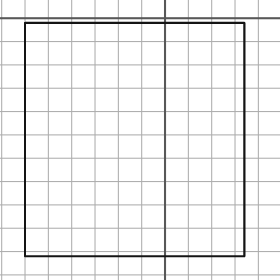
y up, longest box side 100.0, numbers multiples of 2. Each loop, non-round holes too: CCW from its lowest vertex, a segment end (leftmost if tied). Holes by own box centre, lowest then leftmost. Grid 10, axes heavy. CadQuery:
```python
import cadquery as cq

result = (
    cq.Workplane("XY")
    .moveTo(-60.0, -102.0)
    .lineTo(34.0, -102.0)
    .lineTo(34.0, -2.0)
    .lineTo(-60.0, -2.0)
    .close()
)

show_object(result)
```